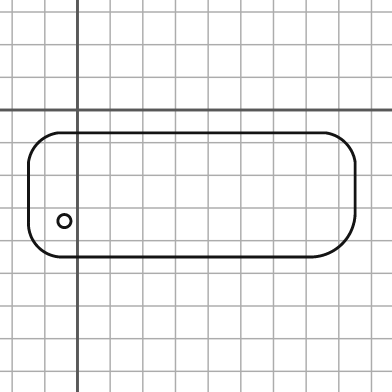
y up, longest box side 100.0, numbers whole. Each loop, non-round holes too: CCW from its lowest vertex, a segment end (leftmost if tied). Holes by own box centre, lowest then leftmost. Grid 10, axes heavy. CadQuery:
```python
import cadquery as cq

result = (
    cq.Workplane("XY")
    .moveTo(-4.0, -45.0)
    .lineTo(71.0, -45.0)
    .threePointArc((81.0, -41.0), (85.0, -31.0))
    .lineTo(85.0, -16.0)
    .threePointArc((82.0, -10.0), (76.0, -7.0))
    .lineTo(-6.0, -7.0)
    .threePointArc((-12.0, -10.0), (-15.0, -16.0))
    .lineTo(-15.0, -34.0)
    .threePointArc((-12.0, -42.0), (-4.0, -45.0))
    .close()
    .moveTo(-4.0, -34.0)
    .circle(2.0)
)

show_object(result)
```